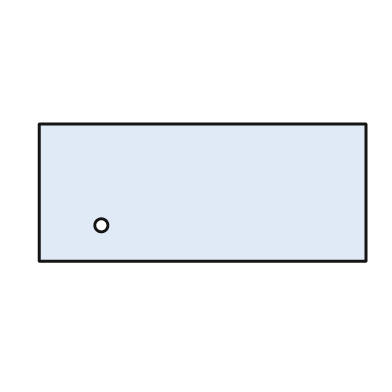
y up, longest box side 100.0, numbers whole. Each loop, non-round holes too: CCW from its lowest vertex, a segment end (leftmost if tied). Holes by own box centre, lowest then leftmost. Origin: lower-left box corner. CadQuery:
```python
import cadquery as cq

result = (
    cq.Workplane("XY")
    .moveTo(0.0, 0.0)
    .lineTo(100.0, 0.0)
    .lineTo(100.0, 42.0)
    .lineTo(0.0, 42.0)
    .close()
    .moveTo(19.0, 11.0)
    .circle(2.0)
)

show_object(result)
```